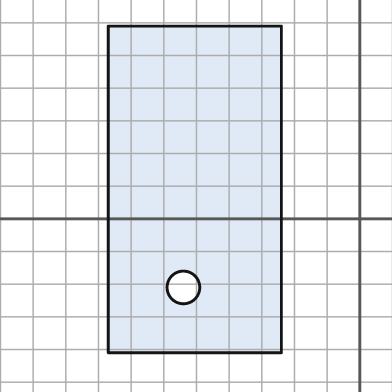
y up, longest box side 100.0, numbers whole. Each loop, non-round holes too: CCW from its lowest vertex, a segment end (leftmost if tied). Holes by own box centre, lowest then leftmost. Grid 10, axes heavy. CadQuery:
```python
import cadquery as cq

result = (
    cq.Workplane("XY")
    .moveTo(-77.0, -41.0)
    .lineTo(-24.0, -41.0)
    .lineTo(-24.0, 59.0)
    .lineTo(-77.0, 59.0)
    .close()
    .moveTo(-54.0, -21.0)
    .circle(5.0)
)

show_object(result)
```